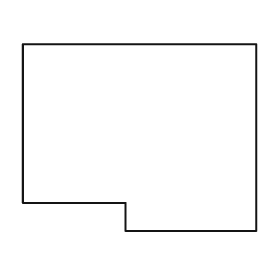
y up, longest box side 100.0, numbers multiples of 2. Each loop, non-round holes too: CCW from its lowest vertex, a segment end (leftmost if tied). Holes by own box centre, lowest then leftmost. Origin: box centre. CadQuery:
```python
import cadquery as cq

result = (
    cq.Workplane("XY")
    .moveTo(-6.0, -40.0)
    .lineTo(50.0, -40.0)
    .lineTo(50.0, 40.0)
    .lineTo(-50.0, 40.0)
    .lineTo(-50.0, -28.0)
    .lineTo(-6.0, -28.0)
    .close()
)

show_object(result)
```